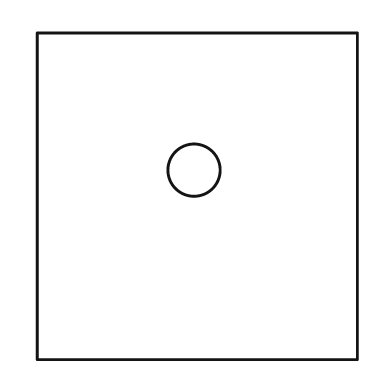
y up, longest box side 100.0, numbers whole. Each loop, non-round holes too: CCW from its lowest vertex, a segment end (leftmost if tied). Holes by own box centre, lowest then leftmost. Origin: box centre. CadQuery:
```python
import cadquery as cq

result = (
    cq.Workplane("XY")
    .moveTo(-49.0, -50.0)
    .lineTo(49.0, -50.0)
    .lineTo(49.0, 50.0)
    .lineTo(-49.0, 50.0)
    .close()
    .moveTo(-1.0, 8.0)
    .circle(8.0)
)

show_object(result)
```